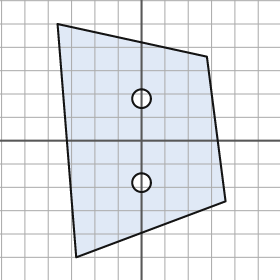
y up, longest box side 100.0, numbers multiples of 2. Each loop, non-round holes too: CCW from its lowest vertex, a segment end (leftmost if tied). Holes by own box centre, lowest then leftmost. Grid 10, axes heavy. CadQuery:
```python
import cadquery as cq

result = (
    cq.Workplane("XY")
    .moveTo(-28.0, -50.0)
    .lineTo(36.0, -26.0)
    .lineTo(28.0, 36.0)
    .lineTo(-36.0, 50.0)
    .close()
    .moveTo(0.0, -18.0)
    .circle(4.0)
    .moveTo(0.0, 18.0)
    .circle(4.0)
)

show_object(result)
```